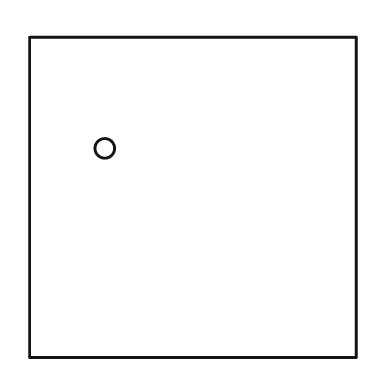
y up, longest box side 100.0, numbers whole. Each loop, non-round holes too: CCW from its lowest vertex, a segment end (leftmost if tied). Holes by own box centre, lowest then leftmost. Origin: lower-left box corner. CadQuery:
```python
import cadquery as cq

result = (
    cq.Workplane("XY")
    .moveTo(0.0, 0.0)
    .lineTo(100.0, 0.0)
    .lineTo(100.0, 98.0)
    .lineTo(0.0, 98.0)
    .close()
    .moveTo(23.0, 64.0)
    .circle(3.0)
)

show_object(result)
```